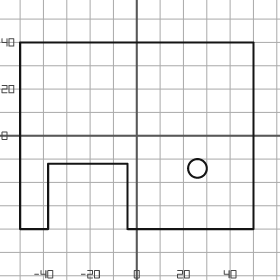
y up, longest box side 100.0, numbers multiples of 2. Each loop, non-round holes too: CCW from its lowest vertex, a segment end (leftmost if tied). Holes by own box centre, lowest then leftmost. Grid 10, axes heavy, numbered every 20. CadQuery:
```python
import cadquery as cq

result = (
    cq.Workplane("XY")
    .moveTo(-50.0, -40.0)
    .lineTo(-38.0, -40.0)
    .lineTo(-38.0, -12.0)
    .lineTo(-4.0, -12.0)
    .lineTo(-4.0, -40.0)
    .lineTo(50.0, -40.0)
    .lineTo(50.0, 40.0)
    .lineTo(-50.0, 40.0)
    .close()
    .moveTo(26.0, -14.0)
    .circle(4.0)
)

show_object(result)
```